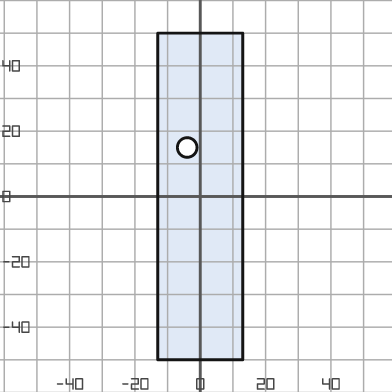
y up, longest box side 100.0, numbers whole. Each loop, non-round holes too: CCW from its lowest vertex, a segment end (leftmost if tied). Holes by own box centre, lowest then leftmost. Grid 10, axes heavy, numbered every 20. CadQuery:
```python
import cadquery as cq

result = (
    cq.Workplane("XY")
    .moveTo(-13.0, -50.0)
    .lineTo(13.0, -50.0)
    .lineTo(13.0, 50.0)
    .lineTo(-13.0, 50.0)
    .close()
    .moveTo(-4.0, 15.0)
    .circle(3.0)
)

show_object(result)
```